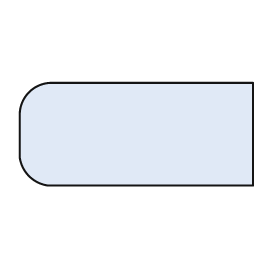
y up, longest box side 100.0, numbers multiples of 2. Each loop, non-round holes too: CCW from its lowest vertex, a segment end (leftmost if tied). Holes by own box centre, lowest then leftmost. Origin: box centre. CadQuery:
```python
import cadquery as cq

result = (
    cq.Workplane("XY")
    .moveTo(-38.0, -22.0)
    .lineTo(50.0, -22.0)
    .lineTo(50.0, 22.0)
    .lineTo(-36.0, 22.0)
    .threePointArc((-46.0, 18.0), (-50.0, 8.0))
    .lineTo(-50.0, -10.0)
    .threePointArc((-46.0, -18.0), (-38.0, -22.0))
    .close()
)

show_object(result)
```